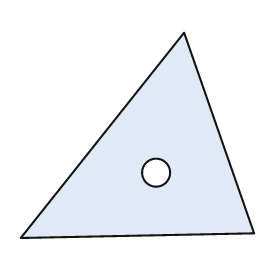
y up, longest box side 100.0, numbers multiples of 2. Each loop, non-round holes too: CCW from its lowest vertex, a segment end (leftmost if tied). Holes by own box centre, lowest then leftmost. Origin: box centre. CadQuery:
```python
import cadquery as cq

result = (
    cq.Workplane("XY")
    .moveTo(-50.0, -44.0)
    .lineTo(50.0, -42.0)
    .lineTo(20.0, 44.0)
    .close()
    .moveTo(8.0, -16.0)
    .circle(6.0)
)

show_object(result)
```